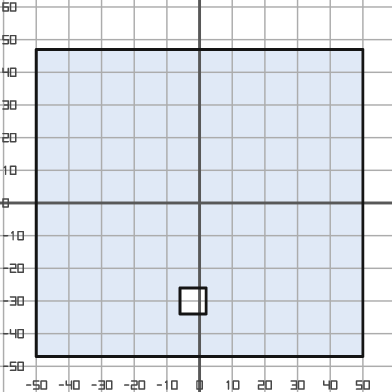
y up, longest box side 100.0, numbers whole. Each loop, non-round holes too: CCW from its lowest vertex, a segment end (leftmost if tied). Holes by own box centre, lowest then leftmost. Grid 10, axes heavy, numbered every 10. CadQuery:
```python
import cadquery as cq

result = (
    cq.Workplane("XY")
    .moveTo(-50.0, -47.0)
    .lineTo(50.0, -47.0)
    .lineTo(50.0, 47.0)
    .lineTo(-50.0, 47.0)
    .close()
    .moveTo(-6.0, -34.0)
    .lineTo(2.0, -34.0)
    .lineTo(2.0, -26.0)
    .lineTo(-6.0, -26.0)
    .close()
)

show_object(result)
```